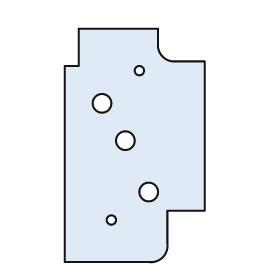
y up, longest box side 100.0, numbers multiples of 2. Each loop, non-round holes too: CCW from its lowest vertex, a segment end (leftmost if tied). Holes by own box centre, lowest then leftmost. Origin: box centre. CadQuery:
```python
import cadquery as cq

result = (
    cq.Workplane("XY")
    .moveTo(-30.0, -50.0)
    .lineTo(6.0, -50.0)
    .threePointArc((12.0, -48.0), (14.0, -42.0))
    .lineTo(14.0, -28.0)
    .lineTo(30.0, -28.0)
    .lineTo(30.0, 36.0)
    .lineTo(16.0, 36.0)
    .threePointArc((12.0, 38.0), (10.0, 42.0))
    .lineTo(10.0, 50.0)
    .lineTo(-24.0, 50.0)
    .lineTo(-24.0, 34.0)
    .lineTo(-30.0, 34.0)
    .close()
    .moveTo(-10.0, -32.0)
    .circle(2.0)
    .moveTo(6.0, -20.0)
    .circle(4.0)
    .moveTo(-4.0, 2.0)
    .circle(4.0)
    .moveTo(-14.0, 18.0)
    .circle(4.0)
    .moveTo(2.0, 32.0)
    .circle(2.0)
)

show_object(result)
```